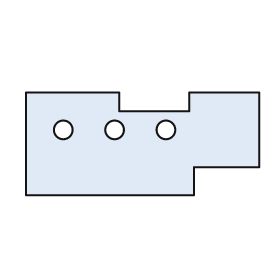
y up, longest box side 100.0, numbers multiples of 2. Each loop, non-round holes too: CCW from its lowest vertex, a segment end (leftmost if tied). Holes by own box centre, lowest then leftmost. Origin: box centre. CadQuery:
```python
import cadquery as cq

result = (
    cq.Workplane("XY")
    .moveTo(-50.0, -22.0)
    .lineTo(22.0, -22.0)
    .lineTo(22.0, -10.0)
    .lineTo(50.0, -10.0)
    .lineTo(50.0, 22.0)
    .lineTo(20.0, 22.0)
    .lineTo(20.0, 14.0)
    .lineTo(-10.0, 14.0)
    .lineTo(-10.0, 22.0)
    .lineTo(-50.0, 22.0)
    .close()
    .moveTo(-34.0, 6.0)
    .circle(4.0)
    .moveTo(-12.0, 6.0)
    .circle(4.0)
    .moveTo(10.0, 6.0)
    .circle(4.0)
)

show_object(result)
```